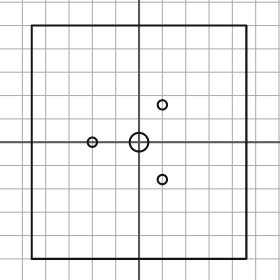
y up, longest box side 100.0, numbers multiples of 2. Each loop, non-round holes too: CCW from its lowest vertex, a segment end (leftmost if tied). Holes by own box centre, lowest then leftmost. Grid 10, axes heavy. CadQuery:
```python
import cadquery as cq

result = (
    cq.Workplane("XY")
    .moveTo(-46.0, -50.0)
    .lineTo(46.0, -50.0)
    .lineTo(46.0, 50.0)
    .lineTo(-46.0, 50.0)
    .close()
    .moveTo(10.0, -16.0)
    .circle(2.0)
    .moveTo(-20.0, 0.0)
    .circle(2.0)
    .moveTo(0.0, 0.0)
    .circle(4.0)
    .moveTo(10.0, 16.0)
    .circle(2.0)
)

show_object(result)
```